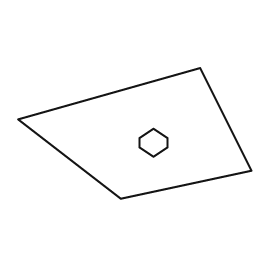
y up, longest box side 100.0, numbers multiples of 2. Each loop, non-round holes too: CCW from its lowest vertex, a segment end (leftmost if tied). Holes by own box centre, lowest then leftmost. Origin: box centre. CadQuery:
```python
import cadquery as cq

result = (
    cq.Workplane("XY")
    .moveTo(-6.0, -28.0)
    .lineTo(50.0, -16.0)
    .lineTo(28.0, 28.0)
    .lineTo(-50.0, 6.0)
    .close()
    .moveTo(8.0, -10.0)
    .lineTo(14.0, -6.0)
    .lineTo(14.0, -2.0)
    .lineTo(8.0, 2.0)
    .lineTo(2.0, -2.0)
    .lineTo(2.0, -6.0)
    .close()
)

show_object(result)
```